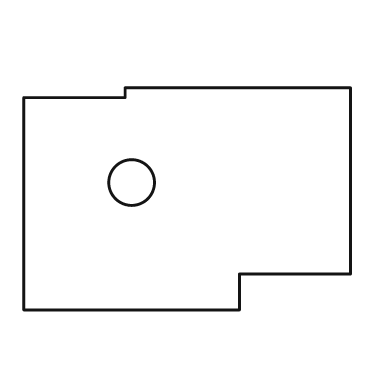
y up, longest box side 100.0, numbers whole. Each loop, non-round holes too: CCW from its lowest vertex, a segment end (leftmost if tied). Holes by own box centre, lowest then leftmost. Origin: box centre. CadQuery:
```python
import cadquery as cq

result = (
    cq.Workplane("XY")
    .moveTo(-50.0, -34.0)
    .lineTo(16.0, -34.0)
    .lineTo(16.0, -23.0)
    .lineTo(50.0, -23.0)
    .lineTo(50.0, 34.0)
    .lineTo(-19.0, 34.0)
    .lineTo(-19.0, 31.0)
    .lineTo(-50.0, 31.0)
    .close()
    .moveTo(-17.0, 5.0)
    .circle(7.0)
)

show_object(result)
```